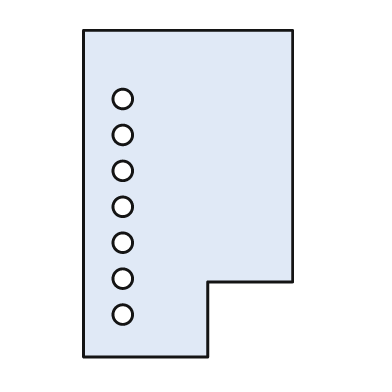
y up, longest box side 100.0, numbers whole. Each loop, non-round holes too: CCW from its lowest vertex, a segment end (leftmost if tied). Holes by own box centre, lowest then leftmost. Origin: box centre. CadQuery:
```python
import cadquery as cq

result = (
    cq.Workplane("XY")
    .moveTo(-32.0, -50.0)
    .lineTo(6.0, -50.0)
    .lineTo(6.0, -27.0)
    .lineTo(32.0, -27.0)
    .lineTo(32.0, 50.0)
    .lineTo(-32.0, 50.0)
    .close()
    .moveTo(-20.0, -37.0)
    .circle(3.0)
    .moveTo(-20.0, -26.0)
    .circle(3.0)
    .moveTo(-20.0, -15.0)
    .circle(3.0)
    .moveTo(-20.0, -4.0)
    .circle(3.0)
    .moveTo(-20.0, 7.0)
    .circle(3.0)
    .moveTo(-20.0, 18.0)
    .circle(3.0)
    .moveTo(-20.0, 29.0)
    .circle(3.0)
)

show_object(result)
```